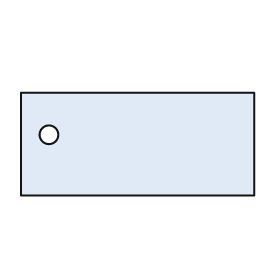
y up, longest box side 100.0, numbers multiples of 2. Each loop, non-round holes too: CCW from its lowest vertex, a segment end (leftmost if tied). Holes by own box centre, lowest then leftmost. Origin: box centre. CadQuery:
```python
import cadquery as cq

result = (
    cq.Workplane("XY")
    .moveTo(-50.0, -22.0)
    .lineTo(50.0, -22.0)
    .lineTo(50.0, 22.0)
    .lineTo(-50.0, 22.0)
    .close()
    .moveTo(-38.0, 4.0)
    .circle(4.0)
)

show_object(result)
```